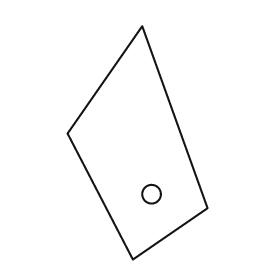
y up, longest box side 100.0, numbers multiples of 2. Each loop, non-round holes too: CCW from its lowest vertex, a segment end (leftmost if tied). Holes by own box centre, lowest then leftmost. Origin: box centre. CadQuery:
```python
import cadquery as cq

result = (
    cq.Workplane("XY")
    .moveTo(-2.0, -50.0)
    .lineTo(30.0, -28.0)
    .lineTo(2.0, 50.0)
    .lineTo(-30.0, 4.0)
    .close()
    .moveTo(6.0, -22.0)
    .circle(4.0)
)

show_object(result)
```